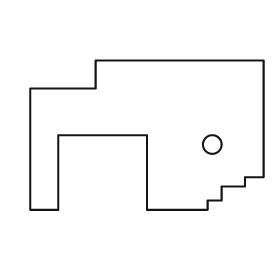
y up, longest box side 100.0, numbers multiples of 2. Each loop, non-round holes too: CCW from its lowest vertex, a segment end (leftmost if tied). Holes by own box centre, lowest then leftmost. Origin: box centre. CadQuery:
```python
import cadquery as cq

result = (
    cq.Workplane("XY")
    .moveTo(-50.0, -32.0)
    .lineTo(-38.0, -32.0)
    .lineTo(-38.0, 0.0)
    .lineTo(0.0, 0.0)
    .lineTo(0.0, -32.0)
    .lineTo(26.0, -32.0)
    .lineTo(26.0, -28.0)
    .lineTo(32.0, -28.0)
    .lineTo(32.0, -22.0)
    .lineTo(42.0, -22.0)
    .lineTo(42.0, -18.0)
    .lineTo(50.0, -18.0)
    .lineTo(50.0, 32.0)
    .lineTo(-22.0, 32.0)
    .lineTo(-22.0, 20.0)
    .lineTo(-50.0, 20.0)
    .close()
    .moveTo(28.0, -4.0)
    .circle(4.0)
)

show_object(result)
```